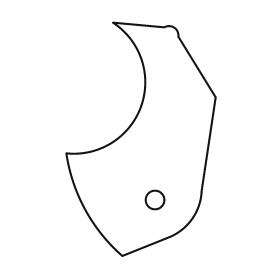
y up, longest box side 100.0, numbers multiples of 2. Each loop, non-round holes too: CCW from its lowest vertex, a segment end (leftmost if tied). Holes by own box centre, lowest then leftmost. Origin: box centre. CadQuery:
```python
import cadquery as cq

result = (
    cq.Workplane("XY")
    .moveTo(-8.0, -50.0)
    .lineTo(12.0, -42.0)
    .threePointArc((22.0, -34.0), (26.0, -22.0))
    .lineTo(32.0, 18.0)
    .lineTo(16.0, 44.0)
    .threePointArc((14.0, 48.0), (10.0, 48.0))
    .lineTo(-12.0, 50.0)
    .threePointArc((0.0, 14.0), (-32.0, -6.0))
    .threePointArc((-24.0, -30.0), (-8.0, -50.0))
    .close()
    .moveTo(6.0, -26.0)
    .circle(4.0)
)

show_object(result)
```